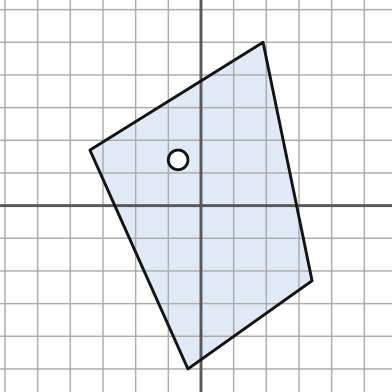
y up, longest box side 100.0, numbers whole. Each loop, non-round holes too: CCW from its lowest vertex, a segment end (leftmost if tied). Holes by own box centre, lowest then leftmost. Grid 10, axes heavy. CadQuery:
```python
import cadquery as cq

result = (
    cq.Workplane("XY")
    .moveTo(-4.0, -50.0)
    .lineTo(34.0, -23.0)
    .lineTo(19.0, 50.0)
    .lineTo(-34.0, 17.0)
    .close()
    .moveTo(-7.0, 14.0)
    .circle(3.0)
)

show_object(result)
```